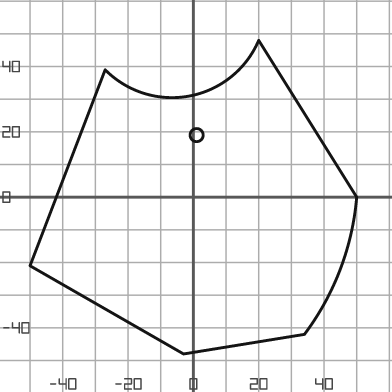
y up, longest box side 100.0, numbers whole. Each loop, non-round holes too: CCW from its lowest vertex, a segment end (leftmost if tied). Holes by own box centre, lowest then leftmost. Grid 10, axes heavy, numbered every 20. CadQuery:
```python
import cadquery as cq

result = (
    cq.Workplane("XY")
    .moveTo(-3.0, -48.0)
    .lineTo(34.0, -42.0)
    .threePointArc((45.0, -22.0), (50.0, 0.0))
    .lineTo(20.0, 48.0)
    .threePointArc((-1.0, 31.0), (-27.0, 39.0))
    .lineTo(-50.0, -21.0)
    .close()
    .moveTo(1.0, 19.0)
    .circle(2.0)
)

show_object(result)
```